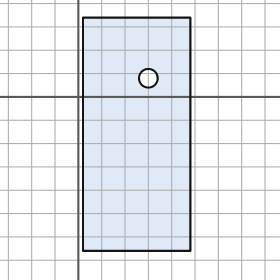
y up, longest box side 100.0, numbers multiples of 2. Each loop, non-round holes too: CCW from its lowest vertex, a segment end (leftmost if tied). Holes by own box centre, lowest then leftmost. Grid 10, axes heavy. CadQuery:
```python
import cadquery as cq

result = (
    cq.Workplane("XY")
    .moveTo(2.0, -66.0)
    .lineTo(48.0, -66.0)
    .lineTo(48.0, 34.0)
    .lineTo(2.0, 34.0)
    .close()
    .moveTo(30.0, 8.0)
    .circle(4.0)
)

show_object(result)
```